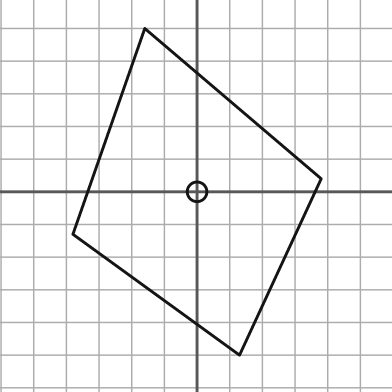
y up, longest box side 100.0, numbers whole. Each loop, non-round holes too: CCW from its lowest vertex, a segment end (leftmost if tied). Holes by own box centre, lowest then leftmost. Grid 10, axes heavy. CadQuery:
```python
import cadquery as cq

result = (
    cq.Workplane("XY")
    .moveTo(13.0, -50.0)
    .lineTo(38.0, 4.0)
    .lineTo(-16.0, 50.0)
    .lineTo(-38.0, -13.0)
    .close()
    .moveTo(0.0, 0.0)
    .circle(3.0)
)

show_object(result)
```